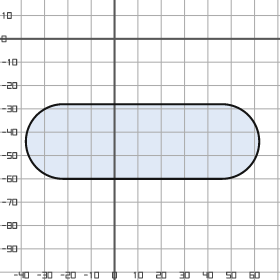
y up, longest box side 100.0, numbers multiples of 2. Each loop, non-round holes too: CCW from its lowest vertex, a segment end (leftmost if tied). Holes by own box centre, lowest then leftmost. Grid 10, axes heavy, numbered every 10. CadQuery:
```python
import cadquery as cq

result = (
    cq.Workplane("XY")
    .moveTo(-22.0, -60.0)
    .lineTo(46.0, -60.0)
    .threePointArc((62.0, -44.0), (46.0, -28.0))
    .lineTo(-22.0, -28.0)
    .threePointArc((-38.0, -44.0), (-22.0, -60.0))
    .close()
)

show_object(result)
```